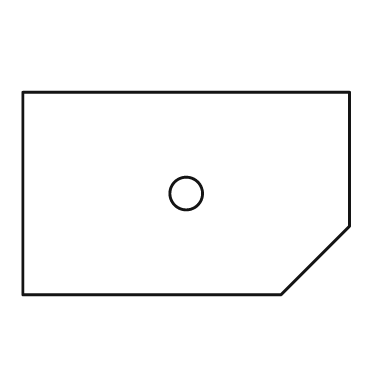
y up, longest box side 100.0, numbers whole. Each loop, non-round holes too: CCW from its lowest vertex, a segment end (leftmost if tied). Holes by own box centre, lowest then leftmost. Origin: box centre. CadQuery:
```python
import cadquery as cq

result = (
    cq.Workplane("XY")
    .moveTo(-50.0, -31.0)
    .lineTo(29.0, -31.0)
    .lineTo(50.0, -10.0)
    .lineTo(50.0, 31.0)
    .lineTo(-50.0, 31.0)
    .close()
    .moveTo(0.0, 0.0)
    .circle(5.0)
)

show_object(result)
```